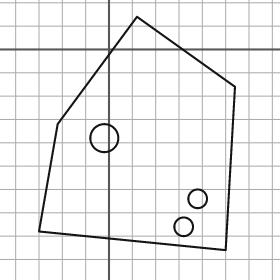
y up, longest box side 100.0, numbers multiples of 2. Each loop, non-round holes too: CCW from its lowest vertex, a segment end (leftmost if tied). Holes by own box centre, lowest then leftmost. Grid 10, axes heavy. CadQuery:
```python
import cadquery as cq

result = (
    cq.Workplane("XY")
    .moveTo(50.0, -86.0)
    .lineTo(54.0, -16.0)
    .lineTo(12.0, 14.0)
    .lineTo(-22.0, -32.0)
    .lineTo(-30.0, -78.0)
    .close()
    .moveTo(32.0, -76.0)
    .circle(4.0)
    .moveTo(38.0, -64.0)
    .circle(4.0)
    .moveTo(-2.0, -38.0)
    .circle(6.0)
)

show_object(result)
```